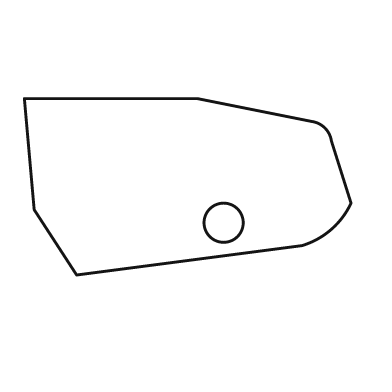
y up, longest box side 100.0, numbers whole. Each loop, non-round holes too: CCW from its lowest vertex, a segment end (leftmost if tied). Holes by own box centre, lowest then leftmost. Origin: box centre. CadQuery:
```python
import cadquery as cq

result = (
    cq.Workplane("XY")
    .moveTo(-34.0, -27.0)
    .lineTo(35.0, -18.0)
    .threePointArc((44.0, -13.0), (50.0, -5.0))
    .lineTo(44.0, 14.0)
    .threePointArc((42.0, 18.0), (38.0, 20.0))
    .lineTo(3.0, 27.0)
    .lineTo(-50.0, 27.0)
    .lineTo(-47.0, -7.0)
    .close()
    .moveTo(11.0, -11.0)
    .circle(6.0)
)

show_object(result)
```